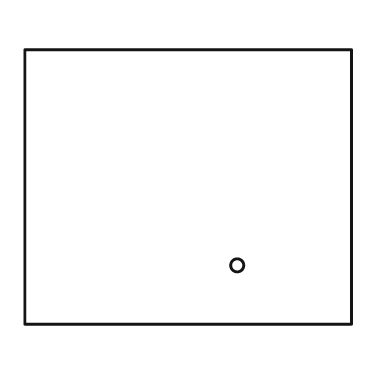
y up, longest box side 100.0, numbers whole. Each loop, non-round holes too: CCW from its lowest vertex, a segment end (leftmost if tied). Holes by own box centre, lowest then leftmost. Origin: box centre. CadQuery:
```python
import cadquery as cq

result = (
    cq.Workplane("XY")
    .moveTo(-50.0, -42.0)
    .lineTo(50.0, -42.0)
    .lineTo(50.0, 42.0)
    .lineTo(-50.0, 42.0)
    .close()
    .moveTo(15.0, -24.0)
    .circle(2.0)
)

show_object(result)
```